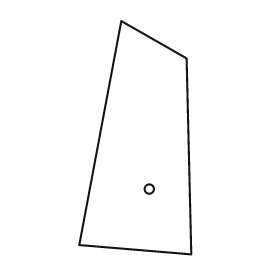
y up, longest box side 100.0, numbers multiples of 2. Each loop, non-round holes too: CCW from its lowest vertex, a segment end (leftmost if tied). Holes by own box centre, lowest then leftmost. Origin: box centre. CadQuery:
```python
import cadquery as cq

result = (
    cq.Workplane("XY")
    .moveTo(24.0, -50.0)
    .lineTo(22.0, 34.0)
    .lineTo(-6.0, 50.0)
    .lineTo(-24.0, -46.0)
    .close()
    .moveTo(6.0, -22.0)
    .circle(2.0)
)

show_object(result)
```